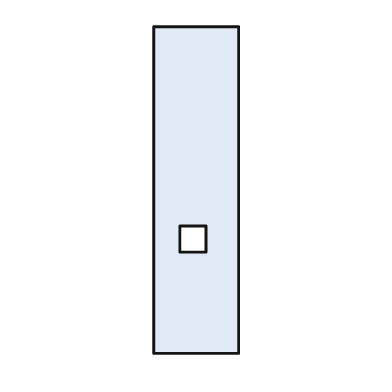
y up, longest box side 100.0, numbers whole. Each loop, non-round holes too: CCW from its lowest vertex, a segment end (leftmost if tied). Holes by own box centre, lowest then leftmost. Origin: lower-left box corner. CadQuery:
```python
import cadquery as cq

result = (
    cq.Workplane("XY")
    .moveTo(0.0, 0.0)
    .lineTo(26.0, 0.0)
    .lineTo(26.0, 100.0)
    .lineTo(0.0, 100.0)
    .close()
    .moveTo(8.0, 31.0)
    .lineTo(16.0, 31.0)
    .lineTo(16.0, 39.0)
    .lineTo(8.0, 39.0)
    .close()
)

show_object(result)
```